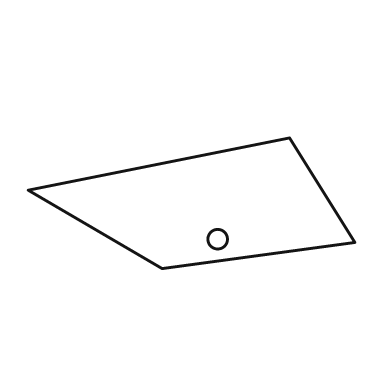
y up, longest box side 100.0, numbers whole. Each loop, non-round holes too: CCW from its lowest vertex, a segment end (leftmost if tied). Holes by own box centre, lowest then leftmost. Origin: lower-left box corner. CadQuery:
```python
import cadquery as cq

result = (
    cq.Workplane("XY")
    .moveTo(41.0, 0.0)
    .lineTo(100.0, 8.0)
    .lineTo(80.0, 40.0)
    .lineTo(0.0, 24.0)
    .close()
    .moveTo(58.0, 9.0)
    .circle(3.0)
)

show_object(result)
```